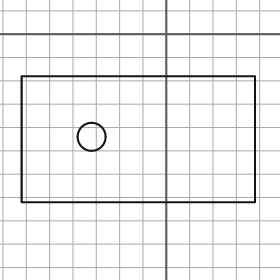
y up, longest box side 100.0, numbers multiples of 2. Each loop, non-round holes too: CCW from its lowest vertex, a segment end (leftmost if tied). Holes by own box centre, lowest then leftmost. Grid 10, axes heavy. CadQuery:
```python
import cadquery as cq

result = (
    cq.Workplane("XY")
    .moveTo(-62.0, -72.0)
    .lineTo(38.0, -72.0)
    .lineTo(38.0, -18.0)
    .lineTo(-62.0, -18.0)
    .close()
    .moveTo(-32.0, -44.0)
    .circle(6.0)
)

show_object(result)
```